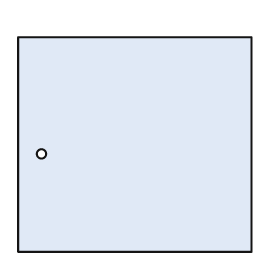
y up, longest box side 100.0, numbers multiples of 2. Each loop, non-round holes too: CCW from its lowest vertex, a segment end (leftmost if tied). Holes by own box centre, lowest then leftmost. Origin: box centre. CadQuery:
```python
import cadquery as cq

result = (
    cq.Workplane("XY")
    .moveTo(-50.0, -46.0)
    .lineTo(50.0, -46.0)
    .lineTo(50.0, 46.0)
    .lineTo(-50.0, 46.0)
    .close()
    .moveTo(-40.0, -4.0)
    .circle(2.0)
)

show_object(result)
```